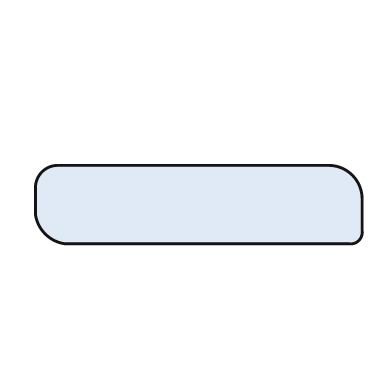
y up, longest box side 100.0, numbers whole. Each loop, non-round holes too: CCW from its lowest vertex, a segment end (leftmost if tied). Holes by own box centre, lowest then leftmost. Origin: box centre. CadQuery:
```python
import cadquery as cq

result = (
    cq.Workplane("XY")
    .moveTo(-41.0, -12.0)
    .lineTo(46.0, -12.0)
    .threePointArc((49.0, -11.0), (50.0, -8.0))
    .lineTo(50.0, 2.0)
    .threePointArc((47.0, 9.0), (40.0, 12.0))
    .lineTo(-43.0, 12.0)
    .threePointArc((-48.0, 10.0), (-50.0, 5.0))
    .lineTo(-50.0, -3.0)
    .threePointArc((-47.0, -9.0), (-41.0, -12.0))
    .close()
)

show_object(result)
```